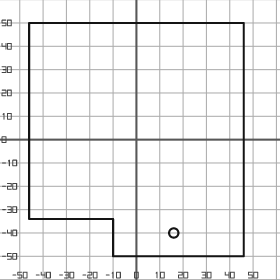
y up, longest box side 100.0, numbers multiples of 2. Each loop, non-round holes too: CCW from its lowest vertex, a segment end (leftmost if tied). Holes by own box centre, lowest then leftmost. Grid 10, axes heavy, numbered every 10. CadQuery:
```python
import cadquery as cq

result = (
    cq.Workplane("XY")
    .moveTo(-10.0, -50.0)
    .lineTo(46.0, -50.0)
    .lineTo(46.0, 50.0)
    .lineTo(-46.0, 50.0)
    .lineTo(-46.0, -34.0)
    .lineTo(-10.0, -34.0)
    .close()
    .moveTo(16.0, -40.0)
    .circle(2.0)
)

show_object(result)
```